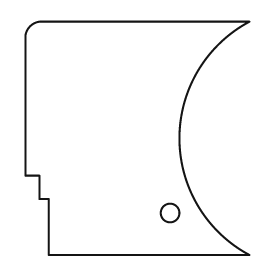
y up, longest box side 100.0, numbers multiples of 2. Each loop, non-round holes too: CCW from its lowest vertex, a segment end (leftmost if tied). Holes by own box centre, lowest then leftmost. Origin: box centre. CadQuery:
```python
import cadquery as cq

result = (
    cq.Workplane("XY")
    .moveTo(-38.0, -50.0)
    .lineTo(48.0, -50.0)
    .threePointArc((18.0, 0.0), (48.0, 50.0))
    .lineTo(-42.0, 50.0)
    .threePointArc((-46.0, 48.0), (-48.0, 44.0))
    .lineTo(-48.0, -16.0)
    .lineTo(-42.0, -16.0)
    .lineTo(-42.0, -26.0)
    .lineTo(-38.0, -26.0)
    .close()
    .moveTo(14.0, -32.0)
    .circle(4.0)
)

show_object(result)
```